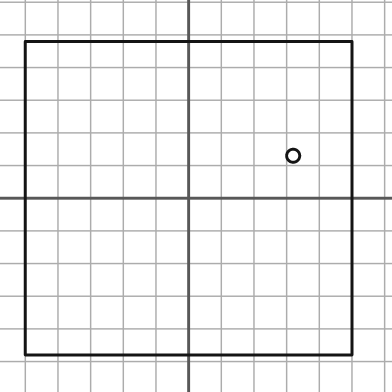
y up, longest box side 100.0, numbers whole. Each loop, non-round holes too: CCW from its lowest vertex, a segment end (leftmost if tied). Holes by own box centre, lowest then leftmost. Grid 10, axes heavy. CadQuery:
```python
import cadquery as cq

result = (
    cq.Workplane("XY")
    .moveTo(-50.0, -48.0)
    .lineTo(50.0, -48.0)
    .lineTo(50.0, 48.0)
    .lineTo(-50.0, 48.0)
    .close()
    .moveTo(32.0, 13.0)
    .circle(2.0)
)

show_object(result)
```